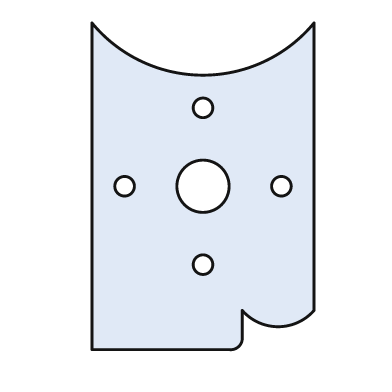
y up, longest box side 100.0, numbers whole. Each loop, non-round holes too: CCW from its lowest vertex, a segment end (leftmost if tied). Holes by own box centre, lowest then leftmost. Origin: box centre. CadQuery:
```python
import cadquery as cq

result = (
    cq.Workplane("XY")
    .moveTo(-34.0, -50.0)
    .lineTo(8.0, -50.0)
    .threePointArc((11.0, -49.0), (12.0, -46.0))
    .lineTo(12.0, -38.0)
    .threePointArc((23.0, -43.0), (34.0, -38.0))
    .lineTo(34.0, 50.0)
    .threePointArc((0.0, 34.0), (-34.0, 50.0))
    .close()
    .moveTo(0.0, -24.0)
    .circle(3.0)
    .moveTo(-24.0, 0.0)
    .circle(3.0)
    .moveTo(0.0, 0.0)
    .circle(8.0)
    .moveTo(24.0, 0.0)
    .circle(3.0)
    .moveTo(0.0, 24.0)
    .circle(3.0)
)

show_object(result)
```